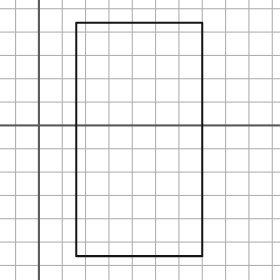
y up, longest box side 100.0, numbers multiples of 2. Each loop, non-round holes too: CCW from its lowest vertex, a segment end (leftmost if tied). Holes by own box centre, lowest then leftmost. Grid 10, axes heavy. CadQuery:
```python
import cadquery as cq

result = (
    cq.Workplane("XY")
    .moveTo(16.0, -56.0)
    .lineTo(70.0, -56.0)
    .lineTo(70.0, 44.0)
    .lineTo(16.0, 44.0)
    .close()
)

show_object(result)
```